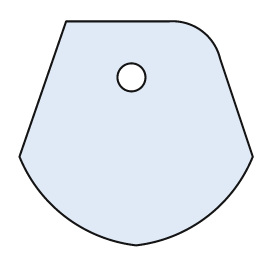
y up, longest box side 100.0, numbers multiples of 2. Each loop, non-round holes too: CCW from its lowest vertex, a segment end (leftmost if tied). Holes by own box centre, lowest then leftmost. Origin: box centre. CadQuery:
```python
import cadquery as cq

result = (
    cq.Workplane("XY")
    .moveTo(0.0, -48.0)
    .threePointArc((30.0, -36.0), (50.0, -10.0))
    .lineTo(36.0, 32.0)
    .threePointArc((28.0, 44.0), (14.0, 48.0))
    .lineTo(-30.0, 48.0)
    .lineTo(-50.0, -10.0)
    .threePointArc((-30.0, -36.0), (0.0, -48.0))
    .close()
    .moveTo(-2.0, 24.0)
    .circle(6.0)
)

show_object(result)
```